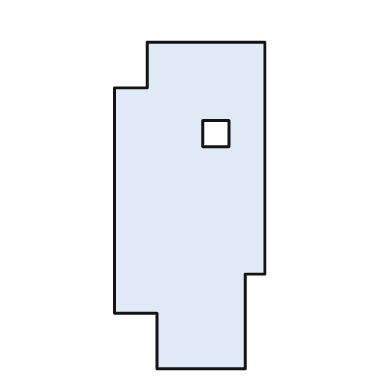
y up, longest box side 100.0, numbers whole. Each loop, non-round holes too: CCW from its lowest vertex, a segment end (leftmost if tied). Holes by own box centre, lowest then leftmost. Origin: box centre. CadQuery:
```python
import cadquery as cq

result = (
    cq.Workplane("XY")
    .moveTo(-10.0, -50.0)
    .lineTo(17.0, -50.0)
    .lineTo(17.0, -21.0)
    .lineTo(23.0, -21.0)
    .lineTo(23.0, 50.0)
    .lineTo(-13.0, 50.0)
    .lineTo(-13.0, 36.0)
    .lineTo(-23.0, 36.0)
    .lineTo(-23.0, -33.0)
    .lineTo(-10.0, -33.0)
    .close()
    .moveTo(4.0, 18.0)
    .lineTo(12.0, 18.0)
    .lineTo(12.0, 26.0)
    .lineTo(4.0, 26.0)
    .close()
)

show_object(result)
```